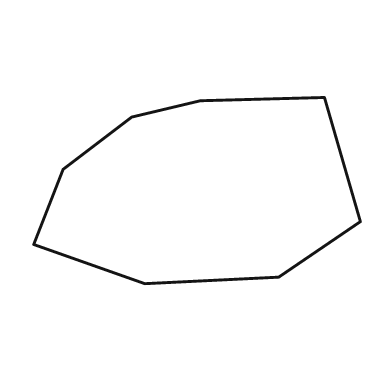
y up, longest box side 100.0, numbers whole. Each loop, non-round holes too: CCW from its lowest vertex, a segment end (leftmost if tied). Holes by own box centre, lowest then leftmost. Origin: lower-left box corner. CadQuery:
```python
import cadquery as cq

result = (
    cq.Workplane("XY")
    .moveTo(34.0, 0.0)
    .lineTo(75.0, 2.0)
    .lineTo(100.0, 19.0)
    .lineTo(89.0, 57.0)
    .lineTo(51.0, 56.0)
    .lineTo(30.0, 51.0)
    .lineTo(9.0, 35.0)
    .lineTo(0.0, 12.0)
    .close()
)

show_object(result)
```